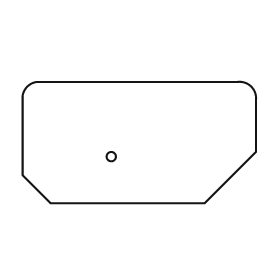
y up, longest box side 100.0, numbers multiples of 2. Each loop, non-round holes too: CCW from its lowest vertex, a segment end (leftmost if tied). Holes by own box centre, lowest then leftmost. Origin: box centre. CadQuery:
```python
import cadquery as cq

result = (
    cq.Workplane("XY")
    .moveTo(-38.0, -26.0)
    .lineTo(28.0, -26.0)
    .lineTo(50.0, -4.0)
    .lineTo(50.0, 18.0)
    .threePointArc((48.0, 24.0), (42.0, 26.0))
    .lineTo(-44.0, 26.0)
    .threePointArc((-48.0, 24.0), (-50.0, 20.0))
    .lineTo(-50.0, -14.0)
    .close()
    .moveTo(-12.0, -6.0)
    .circle(2.0)
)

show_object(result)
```